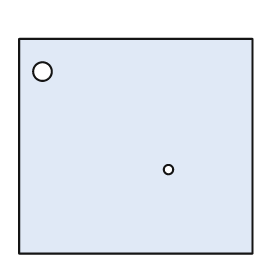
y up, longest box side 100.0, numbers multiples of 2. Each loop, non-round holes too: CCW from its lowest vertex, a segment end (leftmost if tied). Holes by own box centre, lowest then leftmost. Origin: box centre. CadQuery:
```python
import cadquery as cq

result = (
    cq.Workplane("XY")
    .moveTo(-50.0, -46.0)
    .lineTo(50.0, -46.0)
    .lineTo(50.0, 46.0)
    .lineTo(-50.0, 46.0)
    .close()
    .moveTo(14.0, -10.0)
    .circle(2.0)
    .moveTo(-40.0, 32.0)
    .circle(4.0)
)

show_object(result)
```